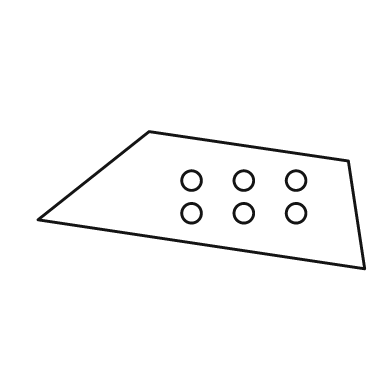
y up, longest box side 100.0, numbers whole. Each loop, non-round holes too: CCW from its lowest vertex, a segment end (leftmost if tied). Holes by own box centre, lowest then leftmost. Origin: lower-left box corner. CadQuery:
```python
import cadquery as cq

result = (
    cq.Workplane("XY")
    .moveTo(100.0, 0.0)
    .lineTo(95.0, 33.0)
    .lineTo(34.0, 42.0)
    .lineTo(0.0, 15.0)
    .close()
    .moveTo(47.0, 17.0)
    .circle(3.0)
    .moveTo(63.0, 17.0)
    .circle(3.0)
    .moveTo(79.0, 17.0)
    .circle(3.0)
    .moveTo(47.0, 27.0)
    .circle(3.0)
    .moveTo(63.0, 27.0)
    .circle(3.0)
    .moveTo(79.0, 27.0)
    .circle(3.0)
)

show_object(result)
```